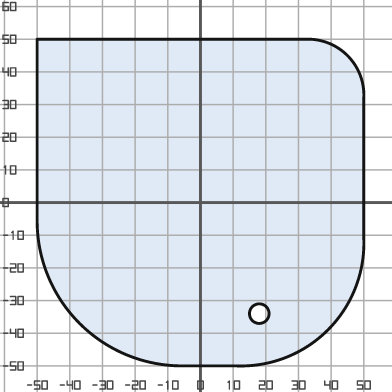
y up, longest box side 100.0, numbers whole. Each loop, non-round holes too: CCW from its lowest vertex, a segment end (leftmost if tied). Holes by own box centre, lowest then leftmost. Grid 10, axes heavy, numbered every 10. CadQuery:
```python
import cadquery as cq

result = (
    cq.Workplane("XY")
    .moveTo(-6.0, -50.0)
    .lineTo(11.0, -50.0)
    .threePointArc((39.0, -39.0), (50.0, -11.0))
    .lineTo(50.0, 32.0)
    .threePointArc((45.0, 45.0), (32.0, 50.0))
    .lineTo(-50.0, 50.0)
    .lineTo(-50.0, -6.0)
    .threePointArc((-37.0, -37.0), (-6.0, -50.0))
    .close()
    .moveTo(18.0, -34.0)
    .circle(3.0)
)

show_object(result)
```